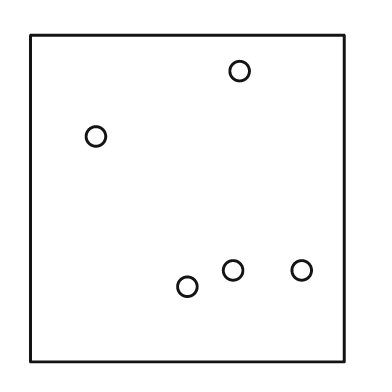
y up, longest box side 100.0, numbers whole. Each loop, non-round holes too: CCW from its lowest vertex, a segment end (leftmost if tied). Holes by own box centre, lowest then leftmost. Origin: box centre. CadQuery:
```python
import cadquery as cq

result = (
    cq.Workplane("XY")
    .moveTo(-48.0, -50.0)
    .lineTo(48.0, -50.0)
    .lineTo(48.0, 50.0)
    .lineTo(-48.0, 50.0)
    .close()
    .moveTo(0.0, -27.0)
    .circle(3.0)
    .moveTo(14.0, -22.0)
    .circle(3.0)
    .moveTo(35.0, -22.0)
    .circle(3.0)
    .moveTo(-28.0, 19.0)
    .circle(3.0)
    .moveTo(16.0, 39.0)
    .circle(3.0)
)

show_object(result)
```